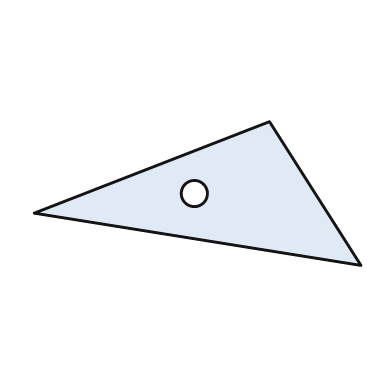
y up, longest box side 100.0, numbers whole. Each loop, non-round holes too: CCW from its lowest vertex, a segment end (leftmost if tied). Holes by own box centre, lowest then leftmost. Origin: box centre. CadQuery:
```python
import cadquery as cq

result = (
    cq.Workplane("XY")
    .moveTo(50.0, -22.0)
    .lineTo(22.0, 22.0)
    .lineTo(-50.0, -6.0)
    .close()
    .moveTo(-1.0, 0.0)
    .circle(4.0)
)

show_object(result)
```